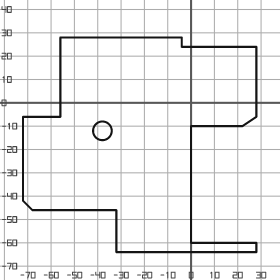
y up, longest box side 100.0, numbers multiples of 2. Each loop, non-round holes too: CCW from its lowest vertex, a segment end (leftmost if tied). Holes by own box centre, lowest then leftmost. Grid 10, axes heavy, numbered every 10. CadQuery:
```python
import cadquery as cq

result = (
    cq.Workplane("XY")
    .moveTo(-32.0, -64.0)
    .lineTo(28.0, -64.0)
    .lineTo(28.0, -60.0)
    .lineTo(0.0, -60.0)
    .lineTo(0.0, -10.0)
    .lineTo(22.0, -10.0)
    .lineTo(28.0, -6.0)
    .lineTo(28.0, 24.0)
    .lineTo(-4.0, 24.0)
    .lineTo(-4.0, 28.0)
    .lineTo(-56.0, 28.0)
    .lineTo(-56.0, -6.0)
    .lineTo(-72.0, -6.0)
    .lineTo(-72.0, -42.0)
    .lineTo(-68.0, -46.0)
    .lineTo(-32.0, -46.0)
    .close()
    .moveTo(-38.0, -12.0)
    .circle(4.0)
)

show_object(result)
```